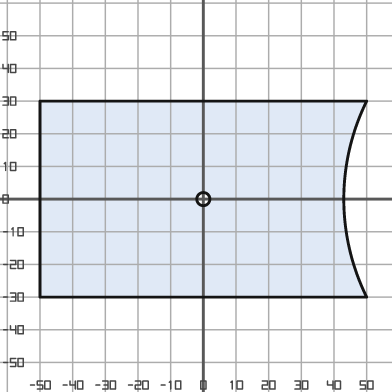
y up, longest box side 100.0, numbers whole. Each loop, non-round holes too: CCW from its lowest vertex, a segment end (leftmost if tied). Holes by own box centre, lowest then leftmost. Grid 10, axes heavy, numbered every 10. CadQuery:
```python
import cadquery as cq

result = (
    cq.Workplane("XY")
    .moveTo(-50.0, -30.0)
    .lineTo(50.0, -30.0)
    .threePointArc((43.0, 0.0), (50.0, 30.0))
    .lineTo(-50.0, 30.0)
    .close()
    .moveTo(0.0, 0.0)
    .circle(2.0)
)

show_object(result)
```